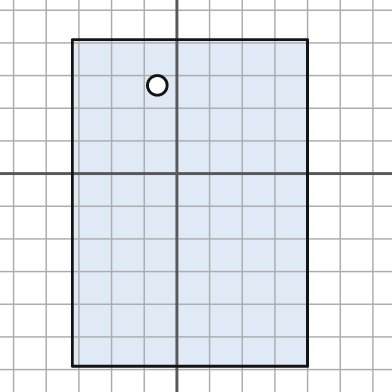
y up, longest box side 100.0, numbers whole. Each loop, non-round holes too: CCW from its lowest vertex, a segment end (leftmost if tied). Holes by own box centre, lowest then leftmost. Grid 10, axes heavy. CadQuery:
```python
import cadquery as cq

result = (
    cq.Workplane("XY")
    .moveTo(-32.0, -59.0)
    .lineTo(40.0, -59.0)
    .lineTo(40.0, 41.0)
    .lineTo(-32.0, 41.0)
    .close()
    .moveTo(-6.0, 27.0)
    .circle(3.0)
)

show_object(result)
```